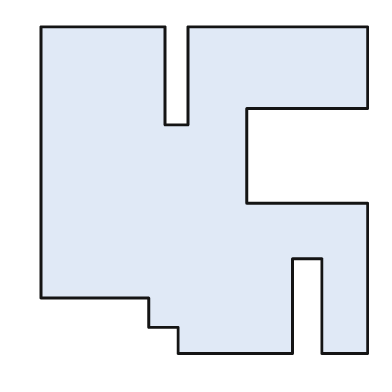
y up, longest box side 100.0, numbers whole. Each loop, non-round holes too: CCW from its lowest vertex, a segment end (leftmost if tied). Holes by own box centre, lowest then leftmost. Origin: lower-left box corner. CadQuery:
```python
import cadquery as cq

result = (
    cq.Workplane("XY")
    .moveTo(42.0, 0.0)
    .lineTo(77.0, 0.0)
    .lineTo(77.0, 29.0)
    .lineTo(86.0, 29.0)
    .lineTo(86.0, 0.0)
    .lineTo(100.0, 0.0)
    .lineTo(100.0, 46.0)
    .lineTo(63.0, 46.0)
    .lineTo(63.0, 75.0)
    .lineTo(100.0, 75.0)
    .lineTo(100.0, 100.0)
    .lineTo(45.0, 100.0)
    .lineTo(45.0, 70.0)
    .lineTo(38.0, 70.0)
    .lineTo(38.0, 100.0)
    .lineTo(0.0, 100.0)
    .lineTo(0.0, 17.0)
    .lineTo(33.0, 17.0)
    .lineTo(33.0, 8.0)
    .lineTo(42.0, 8.0)
    .close()
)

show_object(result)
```